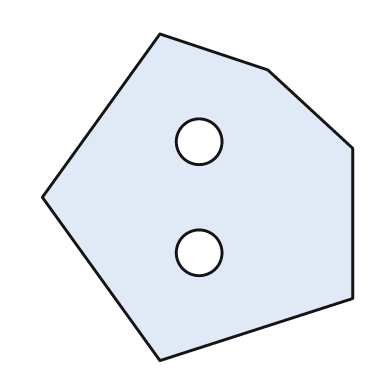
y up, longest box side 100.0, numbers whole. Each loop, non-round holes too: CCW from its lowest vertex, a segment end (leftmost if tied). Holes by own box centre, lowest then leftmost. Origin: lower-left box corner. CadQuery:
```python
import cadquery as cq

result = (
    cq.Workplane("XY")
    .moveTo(36.0, 0.0)
    .lineTo(95.0, 19.0)
    .lineTo(95.0, 65.0)
    .lineTo(69.0, 89.0)
    .lineTo(36.0, 100.0)
    .lineTo(0.0, 50.0)
    .close()
    .moveTo(48.0, 33.0)
    .circle(7.0)
    .moveTo(48.0, 67.0)
    .circle(7.0)
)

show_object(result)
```